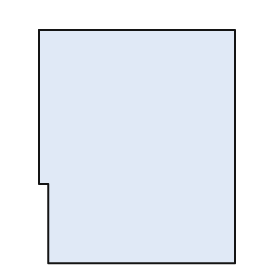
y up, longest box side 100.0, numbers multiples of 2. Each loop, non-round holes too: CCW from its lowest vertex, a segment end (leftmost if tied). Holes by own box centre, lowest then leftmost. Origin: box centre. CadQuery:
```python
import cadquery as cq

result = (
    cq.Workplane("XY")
    .moveTo(-38.0, -50.0)
    .lineTo(42.0, -50.0)
    .lineTo(42.0, 50.0)
    .lineTo(-42.0, 50.0)
    .lineTo(-42.0, -16.0)
    .lineTo(-38.0, -16.0)
    .close()
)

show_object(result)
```